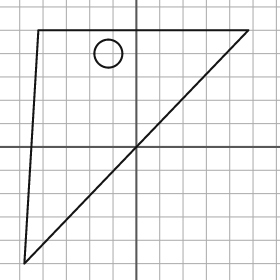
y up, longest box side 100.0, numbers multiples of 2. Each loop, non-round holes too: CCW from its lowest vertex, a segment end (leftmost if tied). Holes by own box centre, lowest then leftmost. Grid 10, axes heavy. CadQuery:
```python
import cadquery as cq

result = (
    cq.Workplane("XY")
    .moveTo(-48.0, -50.0)
    .lineTo(48.0, 50.0)
    .lineTo(-42.0, 50.0)
    .close()
    .moveTo(-12.0, 40.0)
    .circle(6.0)
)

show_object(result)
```